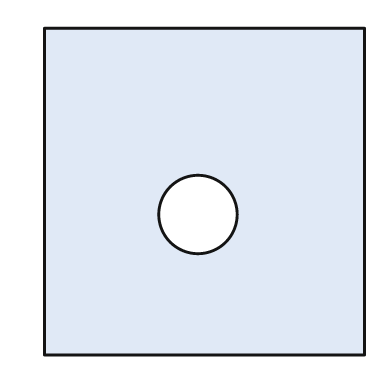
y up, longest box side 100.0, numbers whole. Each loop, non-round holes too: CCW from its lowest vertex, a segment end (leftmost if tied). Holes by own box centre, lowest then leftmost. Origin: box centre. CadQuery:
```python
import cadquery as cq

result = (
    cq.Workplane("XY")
    .moveTo(-49.0, -50.0)
    .lineTo(49.0, -50.0)
    .lineTo(49.0, 50.0)
    .lineTo(-49.0, 50.0)
    .close()
    .moveTo(-2.0, -7.0)
    .circle(12.0)
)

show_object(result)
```